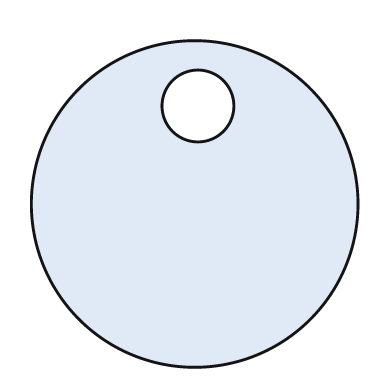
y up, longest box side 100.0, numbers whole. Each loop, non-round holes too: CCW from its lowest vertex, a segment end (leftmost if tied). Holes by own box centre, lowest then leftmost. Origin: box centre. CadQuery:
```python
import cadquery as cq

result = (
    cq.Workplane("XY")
    .moveTo(0.0, 0.0)
    .circle(50.0)
    .moveTo(1.0, 30.0)
    .circle(11.0)
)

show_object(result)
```